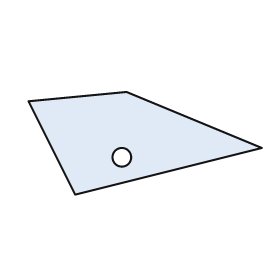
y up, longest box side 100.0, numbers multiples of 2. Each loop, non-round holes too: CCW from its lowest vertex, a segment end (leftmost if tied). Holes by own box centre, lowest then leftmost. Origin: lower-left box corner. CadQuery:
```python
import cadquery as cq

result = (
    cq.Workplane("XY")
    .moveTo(20.0, 0.0)
    .lineTo(100.0, 20.0)
    .lineTo(42.0, 44.0)
    .lineTo(0.0, 40.0)
    .close()
    .moveTo(40.0, 16.0)
    .circle(4.0)
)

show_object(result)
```